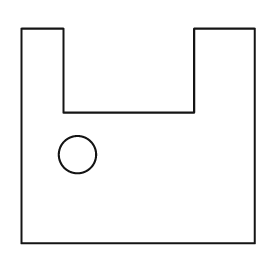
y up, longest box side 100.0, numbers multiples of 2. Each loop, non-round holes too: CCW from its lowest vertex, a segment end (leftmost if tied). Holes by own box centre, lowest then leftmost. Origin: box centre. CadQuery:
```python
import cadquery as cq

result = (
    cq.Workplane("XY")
    .moveTo(-50.0, -46.0)
    .lineTo(50.0, -46.0)
    .lineTo(50.0, 46.0)
    .lineTo(24.0, 46.0)
    .lineTo(24.0, 10.0)
    .lineTo(-32.0, 10.0)
    .lineTo(-32.0, 46.0)
    .lineTo(-50.0, 46.0)
    .close()
    .moveTo(-26.0, -8.0)
    .circle(8.0)
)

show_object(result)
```